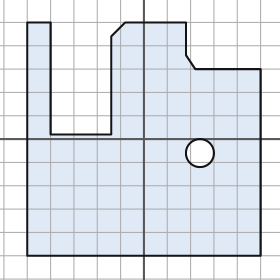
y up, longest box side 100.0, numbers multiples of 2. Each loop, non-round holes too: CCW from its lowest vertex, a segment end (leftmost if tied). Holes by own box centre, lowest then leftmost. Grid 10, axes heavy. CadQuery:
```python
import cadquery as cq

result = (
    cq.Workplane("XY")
    .moveTo(-50.0, -50.0)
    .lineTo(50.0, -50.0)
    .lineTo(50.0, 30.0)
    .lineTo(22.0, 30.0)
    .lineTo(18.0, 36.0)
    .lineTo(18.0, 50.0)
    .lineTo(-8.0, 50.0)
    .lineTo(-14.0, 44.0)
    .lineTo(-14.0, 2.0)
    .lineTo(-40.0, 2.0)
    .lineTo(-40.0, 50.0)
    .lineTo(-50.0, 50.0)
    .close()
    .moveTo(24.0, -6.0)
    .circle(6.0)
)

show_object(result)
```